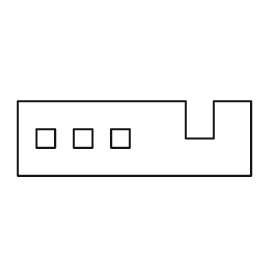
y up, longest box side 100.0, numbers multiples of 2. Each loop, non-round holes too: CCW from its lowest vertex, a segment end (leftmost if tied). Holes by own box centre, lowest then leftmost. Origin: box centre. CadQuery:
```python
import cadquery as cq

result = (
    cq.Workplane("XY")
    .moveTo(-50.0, -16.0)
    .lineTo(50.0, -16.0)
    .lineTo(50.0, 16.0)
    .lineTo(34.0, 16.0)
    .lineTo(34.0, 0.0)
    .lineTo(22.0, 0.0)
    .lineTo(22.0, 16.0)
    .lineTo(-50.0, 16.0)
    .close()
    .moveTo(-42.0, -4.0)
    .lineTo(-34.0, -4.0)
    .lineTo(-34.0, 4.0)
    .lineTo(-42.0, 4.0)
    .close()
    .moveTo(-26.0, -4.0)
    .lineTo(-18.0, -4.0)
    .lineTo(-18.0, 4.0)
    .lineTo(-26.0, 4.0)
    .close()
    .moveTo(-10.0, -4.0)
    .lineTo(-2.0, -4.0)
    .lineTo(-2.0, 4.0)
    .lineTo(-10.0, 4.0)
    .close()
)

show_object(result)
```